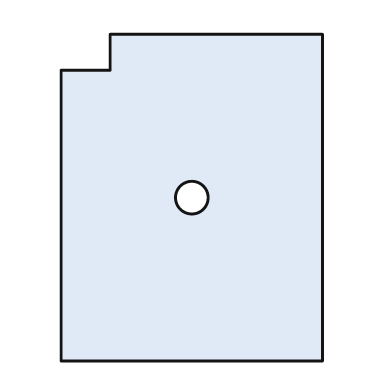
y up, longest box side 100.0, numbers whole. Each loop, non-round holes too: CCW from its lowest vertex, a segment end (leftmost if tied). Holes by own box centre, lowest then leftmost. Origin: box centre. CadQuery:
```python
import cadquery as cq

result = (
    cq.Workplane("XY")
    .moveTo(-40.0, -50.0)
    .lineTo(40.0, -50.0)
    .lineTo(40.0, 50.0)
    .lineTo(-25.0, 50.0)
    .lineTo(-25.0, 39.0)
    .lineTo(-40.0, 39.0)
    .close()
    .moveTo(0.0, 0.0)
    .circle(5.0)
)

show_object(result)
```